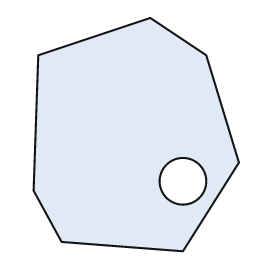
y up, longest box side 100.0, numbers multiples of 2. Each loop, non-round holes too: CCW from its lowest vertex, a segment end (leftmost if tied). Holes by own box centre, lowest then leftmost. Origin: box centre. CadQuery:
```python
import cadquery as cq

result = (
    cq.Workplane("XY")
    .moveTo(20.0, -50.0)
    .lineTo(44.0, -12.0)
    .lineTo(30.0, 34.0)
    .lineTo(6.0, 50.0)
    .lineTo(-42.0, 34.0)
    .lineTo(-44.0, -24.0)
    .lineTo(-32.0, -46.0)
    .close()
    .moveTo(20.0, -20.0)
    .circle(10.0)
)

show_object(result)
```